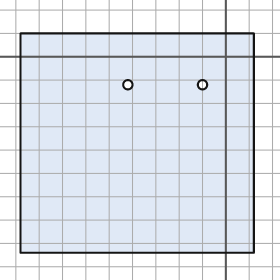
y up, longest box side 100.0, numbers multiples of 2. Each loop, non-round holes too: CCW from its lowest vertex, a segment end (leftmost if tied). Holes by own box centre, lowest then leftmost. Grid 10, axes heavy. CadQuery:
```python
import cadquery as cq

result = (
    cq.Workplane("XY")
    .moveTo(-88.0, -84.0)
    .lineTo(12.0, -84.0)
    .lineTo(12.0, 10.0)
    .lineTo(-88.0, 10.0)
    .close()
    .moveTo(-42.0, -12.0)
    .circle(2.0)
    .moveTo(-10.0, -12.0)
    .circle(2.0)
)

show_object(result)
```